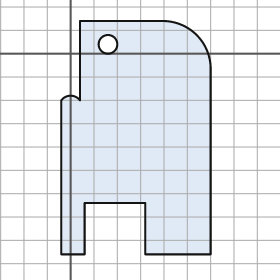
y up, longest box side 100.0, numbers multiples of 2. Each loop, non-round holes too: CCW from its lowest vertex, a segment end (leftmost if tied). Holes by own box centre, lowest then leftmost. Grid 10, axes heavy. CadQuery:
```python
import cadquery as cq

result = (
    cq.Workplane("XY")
    .moveTo(-4.0, -86.0)
    .lineTo(6.0, -86.0)
    .lineTo(6.0, -64.0)
    .lineTo(32.0, -64.0)
    .lineTo(32.0, -86.0)
    .lineTo(60.0, -86.0)
    .lineTo(60.0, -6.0)
    .threePointArc((54.0, 8.0), (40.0, 14.0))
    .lineTo(4.0, 14.0)
    .lineTo(4.0, -20.0)
    .threePointArc((0.0, -18.0), (-4.0, -20.0))
    .close()
    .moveTo(16.0, 4.0)
    .circle(4.0)
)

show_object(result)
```